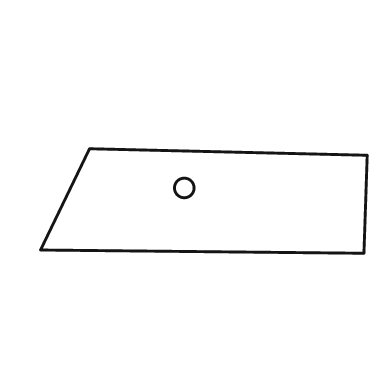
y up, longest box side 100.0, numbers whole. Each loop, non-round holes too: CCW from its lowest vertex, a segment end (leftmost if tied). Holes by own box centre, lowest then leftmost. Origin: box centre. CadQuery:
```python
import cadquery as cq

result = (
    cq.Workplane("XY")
    .moveTo(49.0, -16.0)
    .lineTo(50.0, 14.0)
    .lineTo(-35.0, 16.0)
    .lineTo(-50.0, -15.0)
    .close()
    .moveTo(-6.0, 4.0)
    .circle(3.0)
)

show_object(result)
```